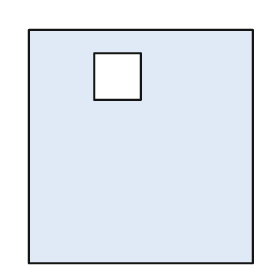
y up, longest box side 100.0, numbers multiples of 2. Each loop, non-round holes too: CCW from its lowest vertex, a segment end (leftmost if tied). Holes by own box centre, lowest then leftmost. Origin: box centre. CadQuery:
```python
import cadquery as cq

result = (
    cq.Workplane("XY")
    .moveTo(-48.0, -50.0)
    .lineTo(48.0, -50.0)
    .lineTo(48.0, 50.0)
    .lineTo(-48.0, 50.0)
    .close()
    .moveTo(-20.0, 20.0)
    .lineTo(0.0, 20.0)
    .lineTo(0.0, 40.0)
    .lineTo(-20.0, 40.0)
    .close()
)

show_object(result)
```